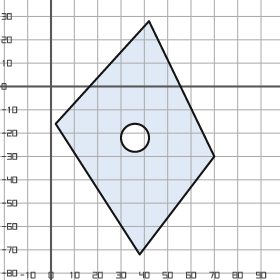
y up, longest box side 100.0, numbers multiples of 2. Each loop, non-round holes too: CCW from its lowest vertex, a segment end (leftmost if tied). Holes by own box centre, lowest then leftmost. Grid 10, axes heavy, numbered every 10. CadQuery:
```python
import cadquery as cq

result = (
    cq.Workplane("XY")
    .moveTo(38.0, -72.0)
    .lineTo(70.0, -30.0)
    .lineTo(42.0, 28.0)
    .lineTo(2.0, -16.0)
    .close()
    .moveTo(36.0, -22.0)
    .circle(6.0)
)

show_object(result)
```